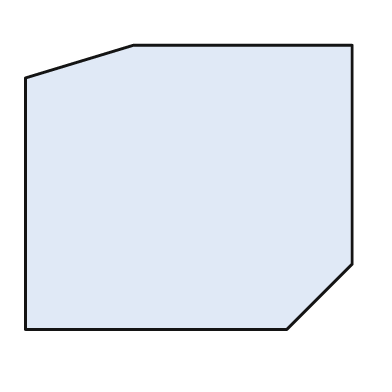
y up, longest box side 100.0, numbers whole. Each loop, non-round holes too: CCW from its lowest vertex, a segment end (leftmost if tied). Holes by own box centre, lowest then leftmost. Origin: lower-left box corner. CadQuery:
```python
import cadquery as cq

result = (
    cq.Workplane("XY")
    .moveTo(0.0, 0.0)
    .lineTo(80.0, 0.0)
    .lineTo(100.0, 20.0)
    .lineTo(100.0, 87.0)
    .lineTo(33.0, 87.0)
    .lineTo(0.0, 77.0)
    .close()
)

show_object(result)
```